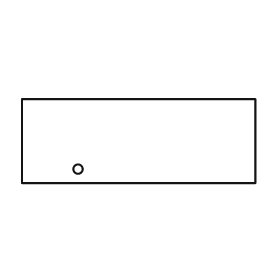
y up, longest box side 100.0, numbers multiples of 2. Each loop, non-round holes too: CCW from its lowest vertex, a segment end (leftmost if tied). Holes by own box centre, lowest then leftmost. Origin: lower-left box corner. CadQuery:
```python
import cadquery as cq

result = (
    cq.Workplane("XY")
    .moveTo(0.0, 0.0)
    .lineTo(100.0, 0.0)
    .lineTo(100.0, 36.0)
    .lineTo(0.0, 36.0)
    .close()
    .moveTo(24.0, 6.0)
    .circle(2.0)
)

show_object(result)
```